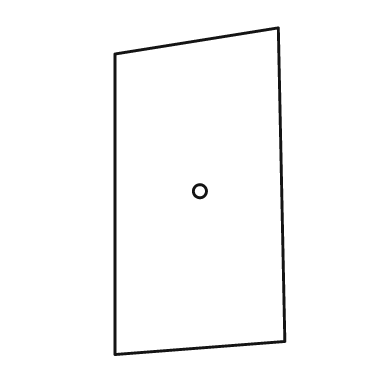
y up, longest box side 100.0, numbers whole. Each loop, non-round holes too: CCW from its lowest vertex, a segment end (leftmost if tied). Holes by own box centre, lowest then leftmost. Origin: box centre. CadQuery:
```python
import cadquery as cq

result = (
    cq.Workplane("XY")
    .moveTo(-26.0, -50.0)
    .lineTo(26.0, -46.0)
    .lineTo(24.0, 50.0)
    .lineTo(-26.0, 42.0)
    .close()
    .moveTo(0.0, 0.0)
    .circle(2.0)
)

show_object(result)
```